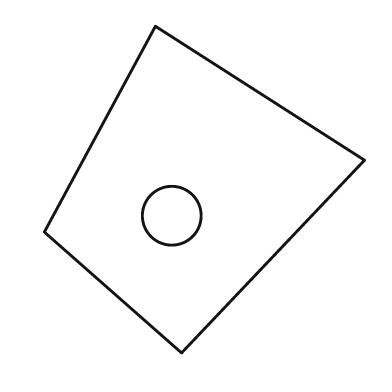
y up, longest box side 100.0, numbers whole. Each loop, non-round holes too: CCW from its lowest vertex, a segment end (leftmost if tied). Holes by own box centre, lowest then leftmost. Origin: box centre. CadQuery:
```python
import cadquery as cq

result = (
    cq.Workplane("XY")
    .moveTo(-7.0, -50.0)
    .lineTo(49.0, 9.0)
    .lineTo(-15.0, 50.0)
    .lineTo(-49.0, -13.0)
    .close()
    .moveTo(-10.0, -8.0)
    .circle(9.0)
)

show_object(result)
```